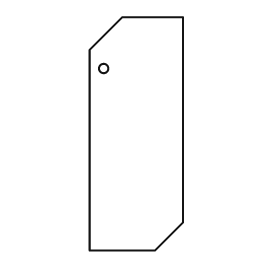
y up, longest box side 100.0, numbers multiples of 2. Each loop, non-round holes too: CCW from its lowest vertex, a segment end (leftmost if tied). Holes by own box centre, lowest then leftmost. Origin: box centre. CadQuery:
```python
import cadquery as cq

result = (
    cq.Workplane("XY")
    .moveTo(-20.0, -50.0)
    .lineTo(8.0, -50.0)
    .lineTo(20.0, -38.0)
    .lineTo(20.0, 50.0)
    .lineTo(-6.0, 50.0)
    .lineTo(-20.0, 36.0)
    .close()
    .moveTo(-14.0, 28.0)
    .circle(2.0)
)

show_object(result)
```